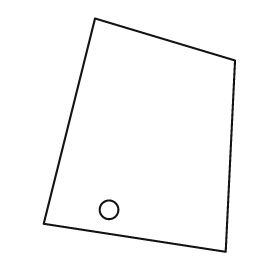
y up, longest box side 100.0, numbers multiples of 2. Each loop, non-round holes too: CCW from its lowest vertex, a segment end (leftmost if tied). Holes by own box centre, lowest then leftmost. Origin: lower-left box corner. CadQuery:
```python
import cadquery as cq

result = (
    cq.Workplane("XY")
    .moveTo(78.0, 0.0)
    .lineTo(82.0, 82.0)
    .lineTo(22.0, 100.0)
    .lineTo(0.0, 12.0)
    .close()
    .moveTo(28.0, 18.0)
    .circle(4.0)
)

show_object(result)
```